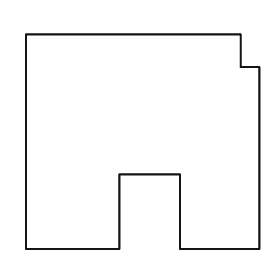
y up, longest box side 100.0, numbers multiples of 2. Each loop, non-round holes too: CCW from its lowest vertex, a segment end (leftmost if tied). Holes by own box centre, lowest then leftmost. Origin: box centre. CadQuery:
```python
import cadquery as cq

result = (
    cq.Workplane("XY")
    .moveTo(-50.0, -46.0)
    .lineTo(-10.0, -46.0)
    .lineTo(-10.0, -14.0)
    .lineTo(16.0, -14.0)
    .lineTo(16.0, -46.0)
    .lineTo(50.0, -46.0)
    .lineTo(50.0, 32.0)
    .lineTo(42.0, 32.0)
    .lineTo(42.0, 46.0)
    .lineTo(-50.0, 46.0)
    .close()
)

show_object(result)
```